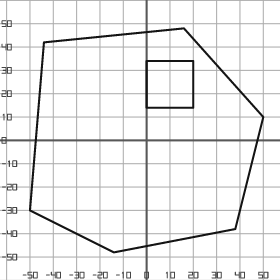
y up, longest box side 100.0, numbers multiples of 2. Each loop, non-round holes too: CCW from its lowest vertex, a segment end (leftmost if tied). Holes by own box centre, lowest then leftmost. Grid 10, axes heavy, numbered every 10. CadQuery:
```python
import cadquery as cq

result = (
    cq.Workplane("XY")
    .moveTo(-14.0, -48.0)
    .lineTo(38.0, -38.0)
    .lineTo(50.0, 10.0)
    .lineTo(16.0, 48.0)
    .lineTo(-44.0, 42.0)
    .lineTo(-50.0, -30.0)
    .close()
    .moveTo(0.0, 14.0)
    .lineTo(20.0, 14.0)
    .lineTo(20.0, 34.0)
    .lineTo(0.0, 34.0)
    .close()
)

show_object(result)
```